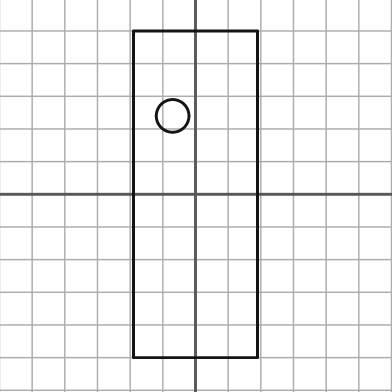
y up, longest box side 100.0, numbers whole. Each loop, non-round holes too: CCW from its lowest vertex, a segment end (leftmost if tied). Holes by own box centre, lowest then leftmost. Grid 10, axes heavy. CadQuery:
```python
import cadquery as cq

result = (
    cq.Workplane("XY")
    .moveTo(-19.0, -50.0)
    .lineTo(19.0, -50.0)
    .lineTo(19.0, 50.0)
    .lineTo(-19.0, 50.0)
    .close()
    .moveTo(-7.0, 24.0)
    .circle(5.0)
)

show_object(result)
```